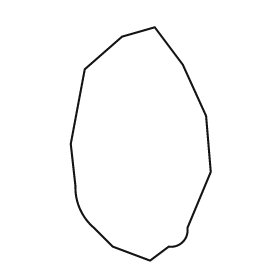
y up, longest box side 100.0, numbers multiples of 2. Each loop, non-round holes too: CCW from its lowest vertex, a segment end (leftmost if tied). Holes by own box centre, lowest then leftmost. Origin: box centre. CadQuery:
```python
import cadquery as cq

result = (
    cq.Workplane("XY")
    .moveTo(4.0, -50.0)
    .lineTo(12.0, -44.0)
    .threePointArc((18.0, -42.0), (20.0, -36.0))
    .lineTo(30.0, -12.0)
    .lineTo(28.0, 12.0)
    .lineTo(18.0, 34.0)
    .lineTo(6.0, 50.0)
    .lineTo(-8.0, 46.0)
    .lineTo(-24.0, 32.0)
    .lineTo(-30.0, 0.0)
    .lineTo(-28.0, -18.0)
    .threePointArc((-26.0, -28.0), (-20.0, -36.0))
    .lineTo(-12.0, -44.0)
    .close()
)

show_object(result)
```